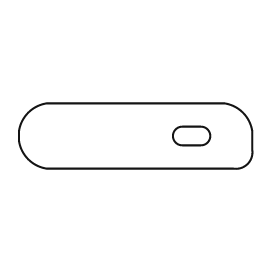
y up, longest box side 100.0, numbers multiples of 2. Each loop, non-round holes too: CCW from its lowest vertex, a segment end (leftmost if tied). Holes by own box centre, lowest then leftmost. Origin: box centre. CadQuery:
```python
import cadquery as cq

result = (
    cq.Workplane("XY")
    .moveTo(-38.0, -14.0)
    .lineTo(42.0, -14.0)
    .threePointArc((48.0, -12.0), (50.0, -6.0))
    .lineTo(50.0, 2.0)
    .threePointArc((46.0, 10.0), (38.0, 14.0))
    .lineTo(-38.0, 14.0)
    .threePointArc((-46.0, 10.0), (-50.0, 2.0))
    .lineTo(-50.0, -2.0)
    .threePointArc((-46.0, -10.0), (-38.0, -14.0))
    .close()
    .moveTo(20.0, -4.0)
    .lineTo(28.0, -4.0)
    .threePointArc((32.0, 0.0), (28.0, 4.0))
    .lineTo(20.0, 4.0)
    .threePointArc((16.0, 0.0), (20.0, -4.0))
    .close()
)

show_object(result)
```